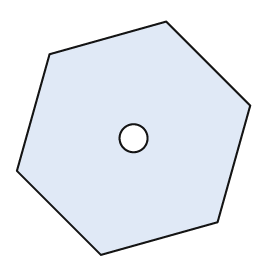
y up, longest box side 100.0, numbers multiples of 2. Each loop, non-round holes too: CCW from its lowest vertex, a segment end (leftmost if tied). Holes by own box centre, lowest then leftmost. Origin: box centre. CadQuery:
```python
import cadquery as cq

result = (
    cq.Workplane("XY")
    .moveTo(-14.0, -50.0)
    .lineTo(36.0, -36.0)
    .lineTo(50.0, 14.0)
    .lineTo(14.0, 50.0)
    .lineTo(-36.0, 36.0)
    .lineTo(-50.0, -14.0)
    .close()
    .moveTo(0.0, 0.0)
    .circle(6.0)
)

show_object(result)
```